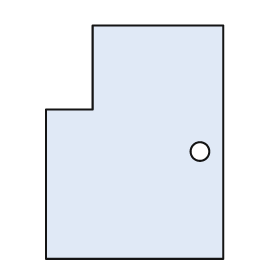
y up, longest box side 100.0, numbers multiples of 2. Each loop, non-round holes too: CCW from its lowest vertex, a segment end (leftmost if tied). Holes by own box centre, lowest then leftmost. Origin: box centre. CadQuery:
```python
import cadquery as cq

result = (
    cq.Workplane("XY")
    .moveTo(-38.0, -50.0)
    .lineTo(38.0, -50.0)
    .lineTo(38.0, 50.0)
    .lineTo(-18.0, 50.0)
    .lineTo(-18.0, 14.0)
    .lineTo(-38.0, 14.0)
    .close()
    .moveTo(28.0, -4.0)
    .circle(4.0)
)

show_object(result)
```